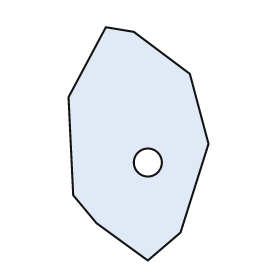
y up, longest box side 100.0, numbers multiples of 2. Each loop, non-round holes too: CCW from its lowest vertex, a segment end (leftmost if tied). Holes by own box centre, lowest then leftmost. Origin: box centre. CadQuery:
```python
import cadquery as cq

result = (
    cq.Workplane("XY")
    .moveTo(4.0, -50.0)
    .lineTo(18.0, -38.0)
    .lineTo(30.0, 0.0)
    .lineTo(22.0, 30.0)
    .lineTo(-2.0, 48.0)
    .lineTo(-14.0, 50.0)
    .lineTo(-30.0, 20.0)
    .lineTo(-28.0, -22.0)
    .lineTo(-18.0, -34.0)
    .close()
    .moveTo(4.0, -8.0)
    .circle(6.0)
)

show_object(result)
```